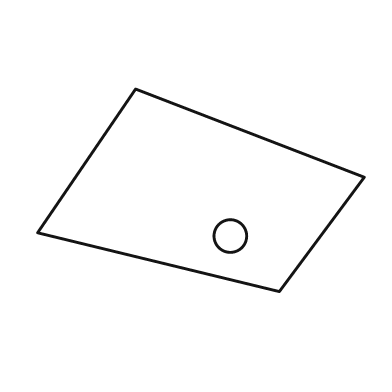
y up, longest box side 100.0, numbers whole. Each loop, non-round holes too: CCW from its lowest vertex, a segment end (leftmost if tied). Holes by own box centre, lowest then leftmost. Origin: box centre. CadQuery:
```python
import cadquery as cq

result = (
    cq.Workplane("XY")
    .moveTo(24.0, -31.0)
    .lineTo(50.0, 4.0)
    .lineTo(-20.0, 31.0)
    .lineTo(-50.0, -13.0)
    .close()
    .moveTo(9.0, -14.0)
    .circle(5.0)
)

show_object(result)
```